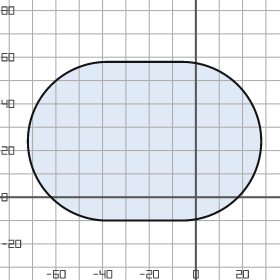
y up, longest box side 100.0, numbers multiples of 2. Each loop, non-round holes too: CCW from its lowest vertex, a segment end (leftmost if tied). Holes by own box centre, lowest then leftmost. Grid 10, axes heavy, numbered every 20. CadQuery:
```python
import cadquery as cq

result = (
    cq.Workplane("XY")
    .moveTo(-38.0, -10.0)
    .lineTo(-6.0, -10.0)
    .threePointArc((28.0, 24.0), (-6.0, 58.0))
    .lineTo(-38.0, 58.0)
    .threePointArc((-72.0, 24.0), (-38.0, -10.0))
    .close()
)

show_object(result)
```